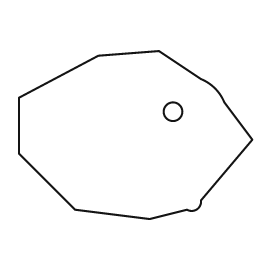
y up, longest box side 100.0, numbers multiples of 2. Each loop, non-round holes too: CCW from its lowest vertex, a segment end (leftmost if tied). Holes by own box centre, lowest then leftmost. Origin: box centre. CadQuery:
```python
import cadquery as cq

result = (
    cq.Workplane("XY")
    .moveTo(6.0, -36.0)
    .lineTo(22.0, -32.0)
    .threePointArc((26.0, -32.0), (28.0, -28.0))
    .lineTo(50.0, -2.0)
    .lineTo(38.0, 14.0)
    .threePointArc((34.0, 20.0), (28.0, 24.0))
    .lineTo(10.0, 36.0)
    .lineTo(-16.0, 34.0)
    .lineTo(-50.0, 16.0)
    .lineTo(-50.0, -8.0)
    .lineTo(-26.0, -32.0)
    .close()
    .moveTo(16.0, 10.0)
    .circle(4.0)
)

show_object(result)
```